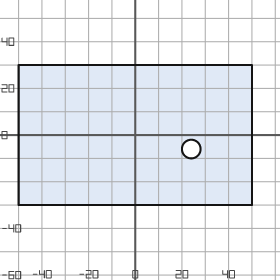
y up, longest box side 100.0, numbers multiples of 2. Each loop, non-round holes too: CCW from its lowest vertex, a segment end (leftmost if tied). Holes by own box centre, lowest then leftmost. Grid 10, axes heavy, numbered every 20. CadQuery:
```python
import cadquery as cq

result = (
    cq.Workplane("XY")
    .moveTo(-50.0, -30.0)
    .lineTo(50.0, -30.0)
    .lineTo(50.0, 30.0)
    .lineTo(-50.0, 30.0)
    .close()
    .moveTo(24.0, -6.0)
    .circle(4.0)
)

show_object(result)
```